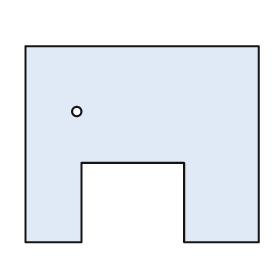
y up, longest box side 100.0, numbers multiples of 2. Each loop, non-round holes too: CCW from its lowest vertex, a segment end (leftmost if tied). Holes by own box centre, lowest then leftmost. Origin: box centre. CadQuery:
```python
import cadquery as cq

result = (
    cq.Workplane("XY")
    .moveTo(-50.0, -42.0)
    .lineTo(-26.0, -42.0)
    .lineTo(-26.0, -8.0)
    .lineTo(18.0, -8.0)
    .lineTo(18.0, -42.0)
    .lineTo(50.0, -42.0)
    .lineTo(50.0, 42.0)
    .lineTo(-50.0, 42.0)
    .close()
    .moveTo(-28.0, 14.0)
    .circle(2.0)
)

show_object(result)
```